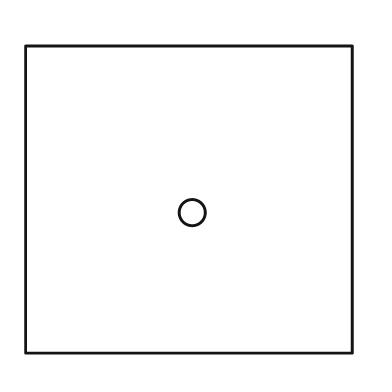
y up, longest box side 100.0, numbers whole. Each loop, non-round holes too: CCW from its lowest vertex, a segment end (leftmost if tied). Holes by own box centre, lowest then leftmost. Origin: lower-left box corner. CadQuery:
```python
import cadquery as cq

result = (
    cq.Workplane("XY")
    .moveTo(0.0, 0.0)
    .lineTo(100.0, 0.0)
    .lineTo(100.0, 94.0)
    .lineTo(0.0, 94.0)
    .close()
    .moveTo(51.0, 43.0)
    .circle(4.0)
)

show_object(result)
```